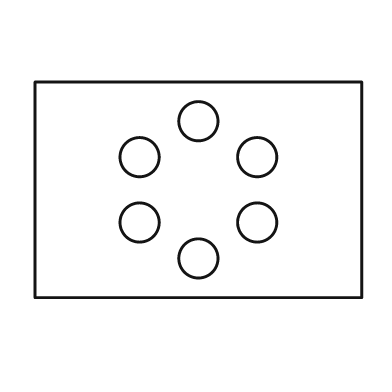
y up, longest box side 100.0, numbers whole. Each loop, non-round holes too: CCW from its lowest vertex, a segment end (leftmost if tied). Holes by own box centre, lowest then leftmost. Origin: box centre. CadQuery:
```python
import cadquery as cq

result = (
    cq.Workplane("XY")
    .moveTo(-50.0, -33.0)
    .lineTo(50.0, -33.0)
    .lineTo(50.0, 33.0)
    .lineTo(-50.0, 33.0)
    .close()
    .moveTo(0.0, -21.0)
    .circle(6.0)
    .moveTo(-18.0, -10.0)
    .circle(6.0)
    .moveTo(18.0, -10.0)
    .circle(6.0)
    .moveTo(-18.0, 10.0)
    .circle(6.0)
    .moveTo(18.0, 10.0)
    .circle(6.0)
    .moveTo(0.0, 21.0)
    .circle(6.0)
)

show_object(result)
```